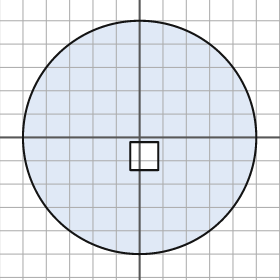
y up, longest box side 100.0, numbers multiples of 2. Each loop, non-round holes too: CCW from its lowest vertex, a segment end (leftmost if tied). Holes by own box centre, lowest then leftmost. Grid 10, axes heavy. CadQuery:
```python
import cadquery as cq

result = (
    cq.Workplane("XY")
    .moveTo(0.0, 0.0)
    .circle(50.0)
    .moveTo(-4.0, -14.0)
    .lineTo(8.0, -14.0)
    .lineTo(8.0, -2.0)
    .lineTo(-4.0, -2.0)
    .close()
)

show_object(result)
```